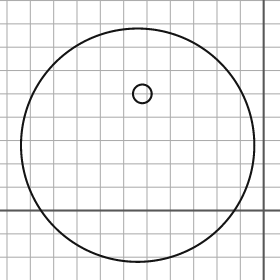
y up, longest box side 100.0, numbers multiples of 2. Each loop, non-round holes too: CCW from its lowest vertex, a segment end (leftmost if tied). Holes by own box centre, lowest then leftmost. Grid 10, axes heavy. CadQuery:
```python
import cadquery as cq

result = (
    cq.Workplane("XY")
    .moveTo(-54.0, 28.0)
    .circle(50.0)
    .moveTo(-52.0, 50.0)
    .circle(4.0)
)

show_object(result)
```